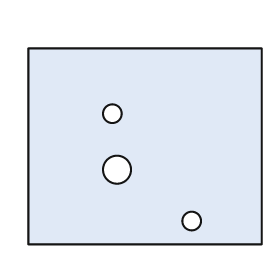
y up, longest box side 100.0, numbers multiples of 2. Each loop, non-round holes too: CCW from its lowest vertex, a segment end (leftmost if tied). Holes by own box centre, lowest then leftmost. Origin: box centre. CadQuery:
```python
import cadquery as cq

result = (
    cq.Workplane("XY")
    .moveTo(-50.0, -42.0)
    .lineTo(50.0, -42.0)
    .lineTo(50.0, 42.0)
    .lineTo(-50.0, 42.0)
    .close()
    .moveTo(20.0, -32.0)
    .circle(4.0)
    .moveTo(-12.0, -10.0)
    .circle(6.0)
    .moveTo(-14.0, 14.0)
    .circle(4.0)
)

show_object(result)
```